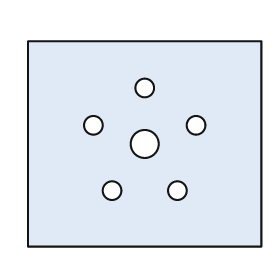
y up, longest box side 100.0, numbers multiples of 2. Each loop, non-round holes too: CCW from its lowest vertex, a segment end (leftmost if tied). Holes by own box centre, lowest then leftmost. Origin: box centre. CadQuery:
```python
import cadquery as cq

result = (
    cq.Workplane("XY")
    .moveTo(-50.0, -44.0)
    .lineTo(50.0, -44.0)
    .lineTo(50.0, 44.0)
    .lineTo(-50.0, 44.0)
    .close()
    .moveTo(-14.0, -20.0)
    .circle(4.0)
    .moveTo(14.0, -20.0)
    .circle(4.0)
    .moveTo(0.0, 0.0)
    .circle(6.0)
    .moveTo(-22.0, 8.0)
    .circle(4.0)
    .moveTo(22.0, 8.0)
    .circle(4.0)
    .moveTo(0.0, 24.0)
    .circle(4.0)
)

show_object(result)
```